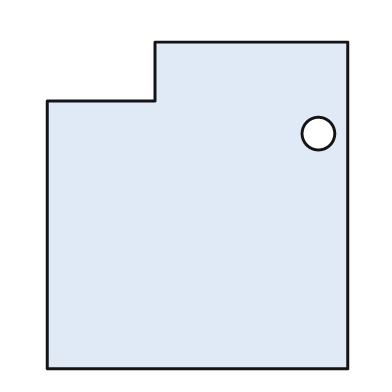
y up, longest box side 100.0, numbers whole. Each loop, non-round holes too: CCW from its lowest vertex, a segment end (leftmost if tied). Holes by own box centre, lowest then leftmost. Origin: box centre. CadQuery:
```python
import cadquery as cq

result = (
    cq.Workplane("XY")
    .moveTo(-46.0, -50.0)
    .lineTo(46.0, -50.0)
    .lineTo(46.0, 50.0)
    .lineTo(-13.0, 50.0)
    .lineTo(-13.0, 32.0)
    .lineTo(-46.0, 32.0)
    .close()
    .moveTo(37.0, 22.0)
    .circle(5.0)
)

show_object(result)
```